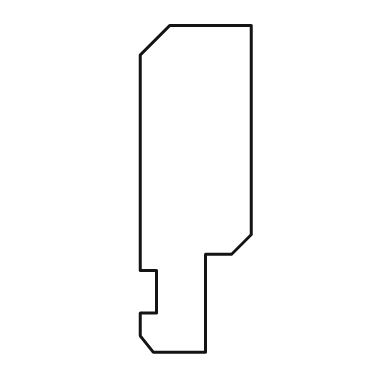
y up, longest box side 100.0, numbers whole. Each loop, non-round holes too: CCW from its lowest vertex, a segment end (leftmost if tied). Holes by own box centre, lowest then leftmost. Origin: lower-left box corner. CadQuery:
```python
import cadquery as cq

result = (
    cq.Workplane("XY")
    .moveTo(4.0, 0.0)
    .lineTo(20.0, 0.0)
    .lineTo(20.0, 30.0)
    .lineTo(28.0, 30.0)
    .lineTo(34.0, 36.0)
    .lineTo(34.0, 100.0)
    .lineTo(9.0, 100.0)
    .lineTo(0.0, 91.0)
    .lineTo(0.0, 25.0)
    .lineTo(5.0, 25.0)
    .lineTo(5.0, 12.0)
    .lineTo(0.0, 12.0)
    .lineTo(0.0, 5.0)
    .close()
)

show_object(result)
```